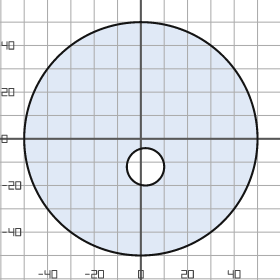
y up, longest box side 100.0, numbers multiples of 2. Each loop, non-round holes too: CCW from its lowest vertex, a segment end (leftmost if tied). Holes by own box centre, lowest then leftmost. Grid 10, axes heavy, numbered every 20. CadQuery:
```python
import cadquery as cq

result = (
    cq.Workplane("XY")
    .moveTo(0.0, 0.0)
    .circle(50.0)
    .moveTo(2.0, -12.0)
    .circle(8.0)
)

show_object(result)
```